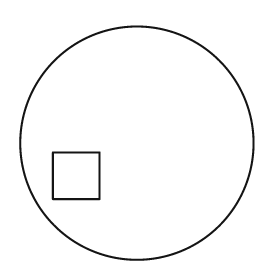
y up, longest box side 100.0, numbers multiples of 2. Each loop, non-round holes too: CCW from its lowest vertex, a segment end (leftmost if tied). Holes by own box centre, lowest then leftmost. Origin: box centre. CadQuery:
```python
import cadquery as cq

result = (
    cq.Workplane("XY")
    .moveTo(0.0, 0.0)
    .circle(50.0)
    .moveTo(-36.0, -24.0)
    .lineTo(-16.0, -24.0)
    .lineTo(-16.0, -4.0)
    .lineTo(-36.0, -4.0)
    .close()
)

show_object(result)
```